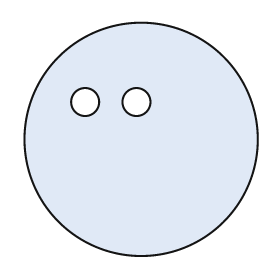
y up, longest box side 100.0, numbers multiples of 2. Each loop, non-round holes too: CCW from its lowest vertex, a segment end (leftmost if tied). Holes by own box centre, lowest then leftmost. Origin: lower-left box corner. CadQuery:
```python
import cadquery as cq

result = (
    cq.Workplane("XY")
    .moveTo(50.0, 50.0)
    .circle(50.0)
    .moveTo(26.0, 66.0)
    .circle(6.0)
    .moveTo(48.0, 66.0)
    .circle(6.0)
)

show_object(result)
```